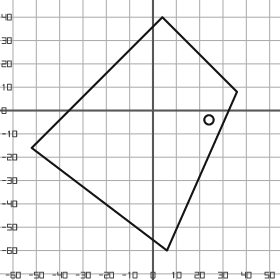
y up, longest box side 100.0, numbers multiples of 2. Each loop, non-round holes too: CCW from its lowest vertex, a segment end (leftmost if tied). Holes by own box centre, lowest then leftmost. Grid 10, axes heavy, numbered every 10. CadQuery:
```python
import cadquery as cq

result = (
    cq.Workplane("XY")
    .moveTo(6.0, -60.0)
    .lineTo(36.0, 8.0)
    .lineTo(4.0, 40.0)
    .lineTo(-52.0, -16.0)
    .close()
    .moveTo(24.0, -4.0)
    .circle(2.0)
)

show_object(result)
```